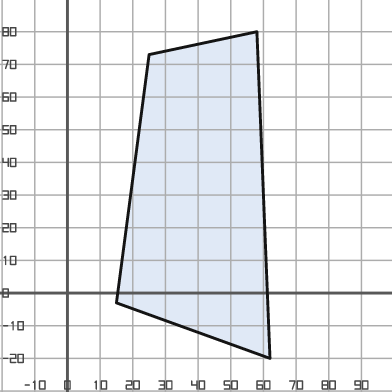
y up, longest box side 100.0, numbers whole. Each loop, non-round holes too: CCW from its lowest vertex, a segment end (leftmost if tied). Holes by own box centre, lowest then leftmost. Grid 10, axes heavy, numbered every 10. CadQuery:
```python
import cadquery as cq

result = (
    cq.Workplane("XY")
    .moveTo(62.0, -20.0)
    .lineTo(58.0, 80.0)
    .lineTo(25.0, 73.0)
    .lineTo(15.0, -3.0)
    .close()
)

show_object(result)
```